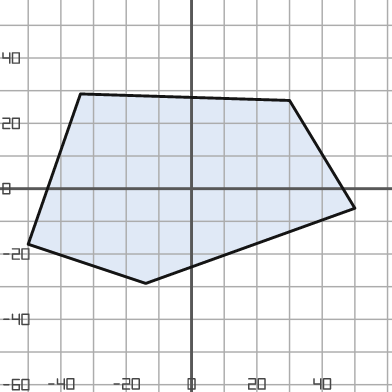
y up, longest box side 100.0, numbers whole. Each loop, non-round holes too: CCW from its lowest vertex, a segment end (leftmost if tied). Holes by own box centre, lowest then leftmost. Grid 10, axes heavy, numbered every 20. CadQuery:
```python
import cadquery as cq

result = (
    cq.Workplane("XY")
    .moveTo(-14.0, -29.0)
    .lineTo(50.0, -6.0)
    .lineTo(30.0, 27.0)
    .lineTo(-34.0, 29.0)
    .lineTo(-50.0, -17.0)
    .close()
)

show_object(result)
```